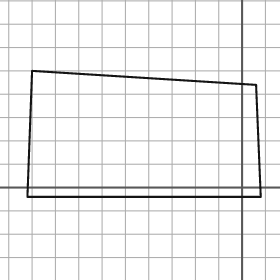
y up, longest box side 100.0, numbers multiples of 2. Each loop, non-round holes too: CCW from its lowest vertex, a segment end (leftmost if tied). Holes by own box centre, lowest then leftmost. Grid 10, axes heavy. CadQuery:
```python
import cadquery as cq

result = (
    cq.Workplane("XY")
    .moveTo(-92.0, -4.0)
    .lineTo(8.0, -4.0)
    .lineTo(6.0, 44.0)
    .lineTo(-90.0, 50.0)
    .close()
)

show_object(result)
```